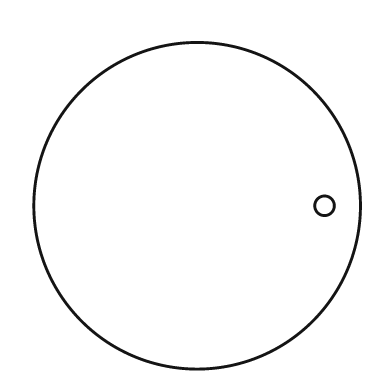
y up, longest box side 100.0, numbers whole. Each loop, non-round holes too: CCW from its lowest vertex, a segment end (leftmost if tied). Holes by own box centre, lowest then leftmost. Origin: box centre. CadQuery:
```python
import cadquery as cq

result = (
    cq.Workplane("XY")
    .moveTo(0.0, 0.0)
    .circle(50.0)
    .moveTo(39.0, 0.0)
    .circle(3.0)
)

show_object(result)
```